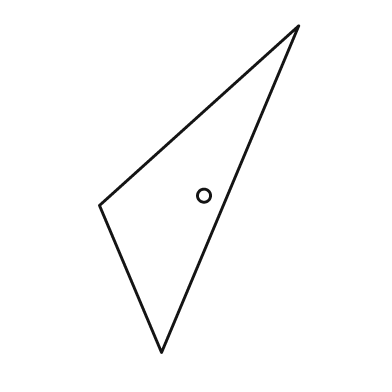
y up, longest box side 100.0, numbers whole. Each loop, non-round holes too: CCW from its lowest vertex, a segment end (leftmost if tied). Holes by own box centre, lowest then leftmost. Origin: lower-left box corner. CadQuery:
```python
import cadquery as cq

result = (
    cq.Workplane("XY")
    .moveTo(19.0, 0.0)
    .lineTo(61.0, 100.0)
    .lineTo(0.0, 45.0)
    .close()
    .moveTo(32.0, 48.0)
    .circle(2.0)
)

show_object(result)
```